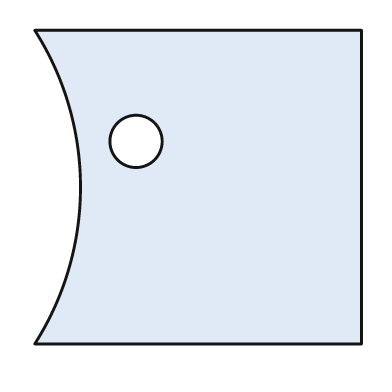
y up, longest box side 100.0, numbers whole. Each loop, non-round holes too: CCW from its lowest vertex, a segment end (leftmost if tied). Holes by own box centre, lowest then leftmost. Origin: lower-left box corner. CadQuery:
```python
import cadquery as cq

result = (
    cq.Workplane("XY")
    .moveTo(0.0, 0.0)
    .lineTo(100.0, 0.0)
    .lineTo(100.0, 96.0)
    .lineTo(0.0, 96.0)
    .threePointArc((14.0, 48.0), (0.0, 0.0))
    .close()
    .moveTo(31.0, 62.0)
    .circle(8.0)
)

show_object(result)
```